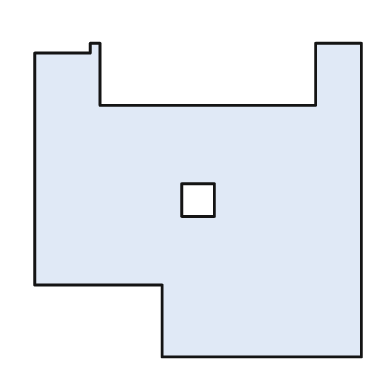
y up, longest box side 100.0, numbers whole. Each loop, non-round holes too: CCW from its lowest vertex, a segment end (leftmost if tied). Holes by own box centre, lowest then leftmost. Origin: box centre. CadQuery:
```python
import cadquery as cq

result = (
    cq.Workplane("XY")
    .moveTo(-11.0, -48.0)
    .lineTo(50.0, -48.0)
    .lineTo(50.0, 48.0)
    .lineTo(36.0, 48.0)
    .lineTo(36.0, 29.0)
    .lineTo(-30.0, 29.0)
    .lineTo(-30.0, 48.0)
    .lineTo(-33.0, 48.0)
    .lineTo(-33.0, 45.0)
    .lineTo(-50.0, 45.0)
    .lineTo(-50.0, -26.0)
    .lineTo(-11.0, -26.0)
    .close()
    .moveTo(-5.0, -5.0)
    .lineTo(5.0, -5.0)
    .lineTo(5.0, 5.0)
    .lineTo(-5.0, 5.0)
    .close()
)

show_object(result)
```